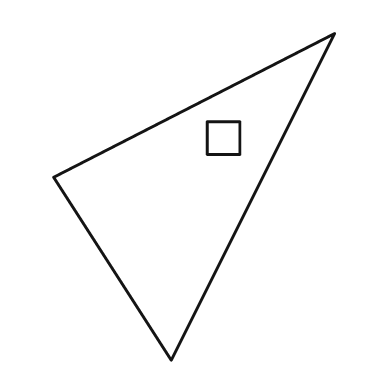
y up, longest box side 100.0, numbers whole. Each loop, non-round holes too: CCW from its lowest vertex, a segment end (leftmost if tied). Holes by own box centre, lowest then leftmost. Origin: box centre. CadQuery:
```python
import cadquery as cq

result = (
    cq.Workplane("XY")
    .moveTo(-7.0, -50.0)
    .lineTo(43.0, 50.0)
    .lineTo(-43.0, 6.0)
    .close()
    .moveTo(4.0, 13.0)
    .lineTo(14.0, 13.0)
    .lineTo(14.0, 23.0)
    .lineTo(4.0, 23.0)
    .close()
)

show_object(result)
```